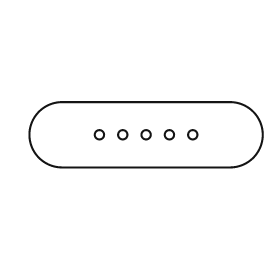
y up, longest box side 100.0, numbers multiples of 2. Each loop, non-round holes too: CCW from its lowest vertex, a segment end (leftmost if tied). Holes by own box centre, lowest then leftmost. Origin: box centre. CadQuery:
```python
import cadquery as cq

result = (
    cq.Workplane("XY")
    .moveTo(-36.0, -14.0)
    .lineTo(36.0, -14.0)
    .threePointArc((50.0, 0.0), (36.0, 14.0))
    .lineTo(-36.0, 14.0)
    .threePointArc((-50.0, 0.0), (-36.0, -14.0))
    .close()
    .moveTo(-20.0, 0.0)
    .circle(2.0)
    .moveTo(-10.0, 0.0)
    .circle(2.0)
    .moveTo(0.0, 0.0)
    .circle(2.0)
    .moveTo(10.0, 0.0)
    .circle(2.0)
    .moveTo(20.0, 0.0)
    .circle(2.0)
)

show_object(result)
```